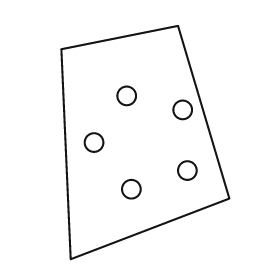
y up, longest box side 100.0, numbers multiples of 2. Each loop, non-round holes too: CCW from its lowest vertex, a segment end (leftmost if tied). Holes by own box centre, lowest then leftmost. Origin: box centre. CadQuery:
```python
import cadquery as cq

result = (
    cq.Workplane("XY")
    .moveTo(-32.0, -50.0)
    .lineTo(36.0, -24.0)
    .lineTo(14.0, 50.0)
    .lineTo(-36.0, 40.0)
    .close()
    .moveTo(-6.0, -20.0)
    .circle(4.0)
    .moveTo(18.0, -12.0)
    .circle(4.0)
    .moveTo(-22.0, 0.0)
    .circle(4.0)
    .moveTo(16.0, 14.0)
    .circle(4.0)
    .moveTo(-8.0, 20.0)
    .circle(4.0)
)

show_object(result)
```